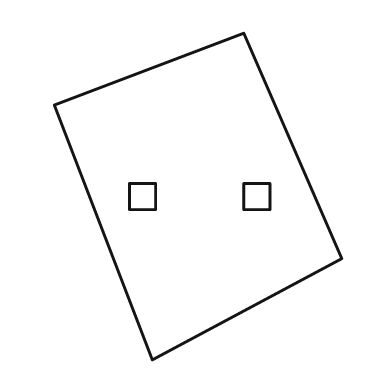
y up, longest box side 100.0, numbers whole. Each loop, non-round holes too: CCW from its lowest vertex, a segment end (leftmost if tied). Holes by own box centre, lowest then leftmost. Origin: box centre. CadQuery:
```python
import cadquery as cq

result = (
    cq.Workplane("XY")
    .moveTo(-14.0, -50.0)
    .lineTo(44.0, -19.0)
    .lineTo(14.0, 50.0)
    .lineTo(-44.0, 28.0)
    .close()
    .moveTo(-21.0, -4.0)
    .lineTo(-13.0, -4.0)
    .lineTo(-13.0, 4.0)
    .lineTo(-21.0, 4.0)
    .close()
    .moveTo(14.0, -4.0)
    .lineTo(22.0, -4.0)
    .lineTo(22.0, 4.0)
    .lineTo(14.0, 4.0)
    .close()
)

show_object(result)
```